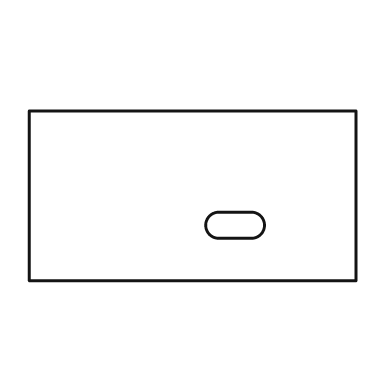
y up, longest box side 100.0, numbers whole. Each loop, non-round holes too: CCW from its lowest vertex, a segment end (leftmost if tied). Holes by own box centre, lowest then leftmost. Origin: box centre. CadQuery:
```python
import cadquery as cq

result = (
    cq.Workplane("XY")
    .moveTo(-50.0, -26.0)
    .lineTo(50.0, -26.0)
    .lineTo(50.0, 26.0)
    .lineTo(-50.0, 26.0)
    .close()
    .moveTo(8.0, -13.0)
    .lineTo(18.0, -13.0)
    .threePointArc((22.0, -9.0), (18.0, -5.0))
    .lineTo(8.0, -5.0)
    .threePointArc((4.0, -9.0), (8.0, -13.0))
    .close()
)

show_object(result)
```